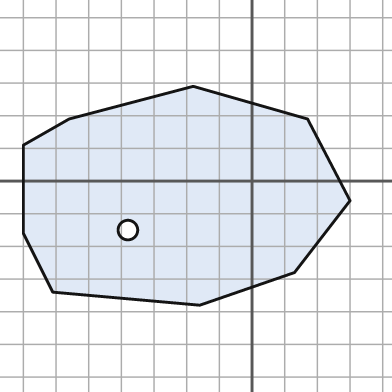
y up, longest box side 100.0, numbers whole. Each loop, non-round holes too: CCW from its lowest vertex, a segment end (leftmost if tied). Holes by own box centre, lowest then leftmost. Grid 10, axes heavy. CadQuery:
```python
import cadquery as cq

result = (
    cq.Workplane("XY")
    .moveTo(-16.0, -38.0)
    .lineTo(13.0, -28.0)
    .lineTo(30.0, -6.0)
    .lineTo(17.0, 19.0)
    .lineTo(-18.0, 29.0)
    .lineTo(-56.0, 19.0)
    .lineTo(-70.0, 11.0)
    .lineTo(-70.0, -16.0)
    .lineTo(-61.0, -34.0)
    .close()
    .moveTo(-38.0, -15.0)
    .circle(3.0)
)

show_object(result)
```